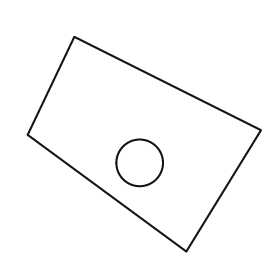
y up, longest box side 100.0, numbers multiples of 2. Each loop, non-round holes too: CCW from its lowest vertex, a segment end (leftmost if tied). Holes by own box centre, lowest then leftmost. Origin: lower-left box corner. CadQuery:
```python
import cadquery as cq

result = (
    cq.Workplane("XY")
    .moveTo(68.0, 0.0)
    .lineTo(100.0, 52.0)
    .lineTo(20.0, 92.0)
    .lineTo(0.0, 50.0)
    .close()
    .moveTo(48.0, 38.0)
    .circle(10.0)
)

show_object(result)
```